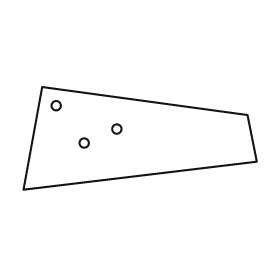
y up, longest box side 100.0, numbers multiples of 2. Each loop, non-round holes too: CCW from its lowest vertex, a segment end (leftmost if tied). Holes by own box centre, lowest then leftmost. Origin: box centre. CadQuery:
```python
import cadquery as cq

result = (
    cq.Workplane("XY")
    .moveTo(-50.0, -22.0)
    .lineTo(50.0, -10.0)
    .lineTo(46.0, 10.0)
    .lineTo(-42.0, 22.0)
    .close()
    .moveTo(-24.0, -2.0)
    .circle(2.0)
    .moveTo(-10.0, 4.0)
    .circle(2.0)
    .moveTo(-36.0, 14.0)
    .circle(2.0)
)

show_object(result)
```